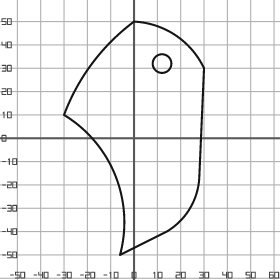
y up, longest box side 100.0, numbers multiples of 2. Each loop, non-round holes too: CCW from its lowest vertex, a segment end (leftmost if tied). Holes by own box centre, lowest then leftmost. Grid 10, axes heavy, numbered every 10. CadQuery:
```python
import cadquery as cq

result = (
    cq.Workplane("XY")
    .moveTo(-6.0, -50.0)
    .lineTo(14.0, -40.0)
    .threePointArc((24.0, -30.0), (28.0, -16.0))
    .lineTo(30.0, 30.0)
    .threePointArc((18.0, 44.0), (0.0, 50.0))
    .threePointArc((-18.0, 32.0), (-30.0, 10.0))
    .threePointArc((-8.0, -16.0), (-6.0, -50.0))
    .close()
    .moveTo(12.0, 32.0)
    .circle(4.0)
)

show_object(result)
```